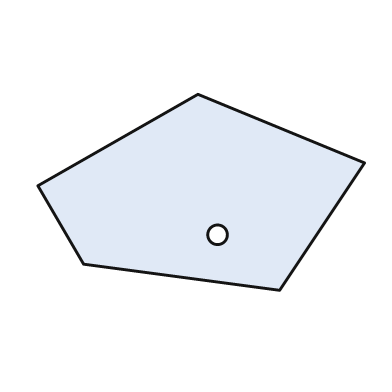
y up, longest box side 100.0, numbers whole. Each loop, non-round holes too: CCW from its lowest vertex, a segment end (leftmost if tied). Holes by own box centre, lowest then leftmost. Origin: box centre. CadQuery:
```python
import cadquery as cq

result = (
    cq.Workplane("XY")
    .moveTo(24.0, -30.0)
    .lineTo(50.0, 9.0)
    .lineTo(-1.0, 30.0)
    .lineTo(-50.0, 2.0)
    .lineTo(-36.0, -22.0)
    .close()
    .moveTo(5.0, -13.0)
    .circle(3.0)
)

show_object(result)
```